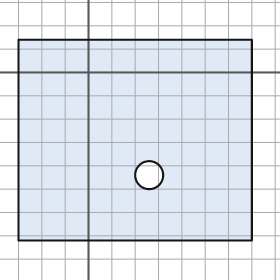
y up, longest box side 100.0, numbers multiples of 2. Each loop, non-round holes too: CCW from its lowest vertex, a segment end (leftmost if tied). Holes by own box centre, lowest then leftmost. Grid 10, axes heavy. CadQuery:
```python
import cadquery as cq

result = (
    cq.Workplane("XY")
    .moveTo(-30.0, -72.0)
    .lineTo(70.0, -72.0)
    .lineTo(70.0, 14.0)
    .lineTo(-30.0, 14.0)
    .close()
    .moveTo(26.0, -44.0)
    .circle(6.0)
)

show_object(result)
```